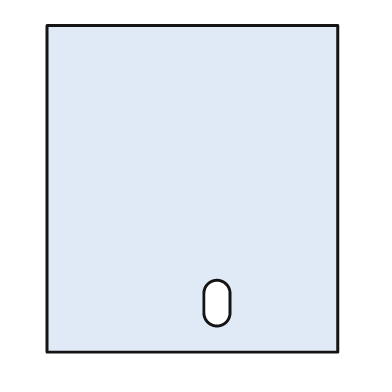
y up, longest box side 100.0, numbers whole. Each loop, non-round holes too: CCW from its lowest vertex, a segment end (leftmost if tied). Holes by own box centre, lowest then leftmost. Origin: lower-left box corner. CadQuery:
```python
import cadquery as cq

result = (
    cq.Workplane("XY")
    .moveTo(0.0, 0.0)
    .lineTo(89.0, 0.0)
    .lineTo(89.0, 100.0)
    .lineTo(0.0, 100.0)
    .close()
    .moveTo(48.0, 12.0)
    .threePointArc((52.0, 8.0), (56.0, 12.0))
    .lineTo(56.0, 18.0)
    .threePointArc((52.0, 22.0), (48.0, 18.0))
    .close()
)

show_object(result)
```